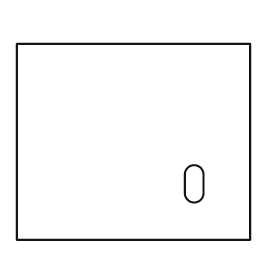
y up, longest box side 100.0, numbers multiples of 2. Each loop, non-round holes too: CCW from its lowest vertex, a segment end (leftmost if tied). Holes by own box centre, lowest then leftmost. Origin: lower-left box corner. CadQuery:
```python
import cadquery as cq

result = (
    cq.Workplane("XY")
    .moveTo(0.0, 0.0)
    .lineTo(100.0, 0.0)
    .lineTo(100.0, 84.0)
    .lineTo(0.0, 84.0)
    .close()
    .moveTo(72.0, 20.0)
    .threePointArc((76.0, 16.0), (80.0, 20.0))
    .lineTo(80.0, 28.0)
    .threePointArc((76.0, 32.0), (72.0, 28.0))
    .close()
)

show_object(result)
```